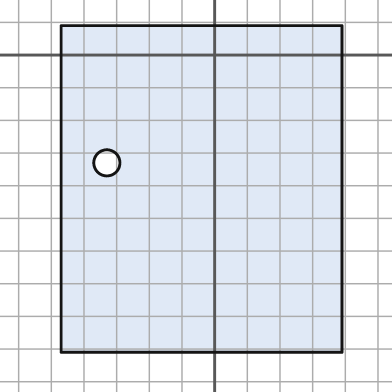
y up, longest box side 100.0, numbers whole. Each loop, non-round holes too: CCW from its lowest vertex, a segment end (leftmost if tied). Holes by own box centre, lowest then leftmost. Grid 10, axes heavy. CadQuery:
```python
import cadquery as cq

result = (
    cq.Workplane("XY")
    .moveTo(-47.0, -91.0)
    .lineTo(39.0, -91.0)
    .lineTo(39.0, 9.0)
    .lineTo(-47.0, 9.0)
    .close()
    .moveTo(-33.0, -33.0)
    .circle(4.0)
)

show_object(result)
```